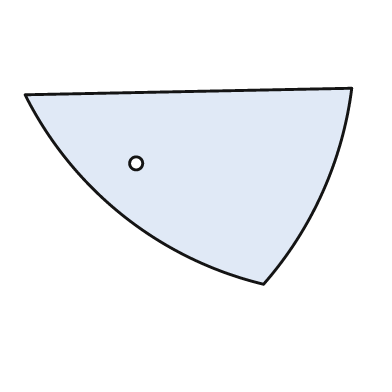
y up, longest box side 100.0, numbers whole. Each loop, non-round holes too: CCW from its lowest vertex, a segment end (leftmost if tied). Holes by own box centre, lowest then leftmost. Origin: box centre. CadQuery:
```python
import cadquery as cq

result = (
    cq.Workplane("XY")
    .moveTo(23.0, -30.0)
    .threePointArc((41.0, -2.0), (50.0, 30.0))
    .lineTo(-50.0, 28.0)
    .threePointArc((-20.0, -9.0), (23.0, -30.0))
    .close()
    .moveTo(-16.0, 7.0)
    .circle(2.0)
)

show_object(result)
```